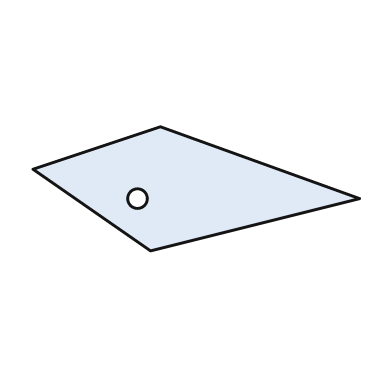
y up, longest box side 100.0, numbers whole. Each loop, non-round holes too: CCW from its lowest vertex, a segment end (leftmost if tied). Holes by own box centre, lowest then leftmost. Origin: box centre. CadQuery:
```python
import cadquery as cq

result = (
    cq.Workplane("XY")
    .moveTo(-14.0, -19.0)
    .lineTo(50.0, -3.0)
    .lineTo(-11.0, 19.0)
    .lineTo(-50.0, 6.0)
    .close()
    .moveTo(-18.0, -3.0)
    .circle(3.0)
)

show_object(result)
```